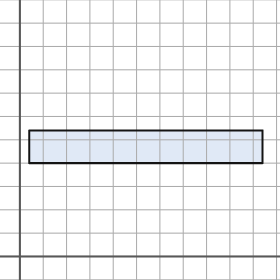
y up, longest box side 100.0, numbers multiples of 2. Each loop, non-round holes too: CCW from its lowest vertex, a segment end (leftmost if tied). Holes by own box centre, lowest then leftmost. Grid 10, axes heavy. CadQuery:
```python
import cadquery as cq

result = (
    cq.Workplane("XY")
    .moveTo(4.0, 40.0)
    .lineTo(104.0, 40.0)
    .lineTo(104.0, 54.0)
    .lineTo(4.0, 54.0)
    .close()
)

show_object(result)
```